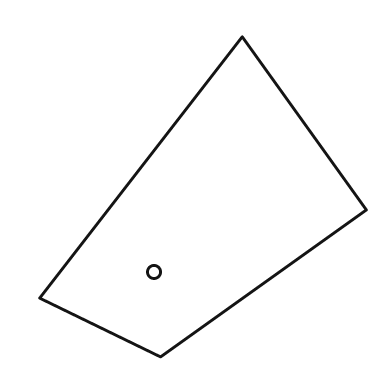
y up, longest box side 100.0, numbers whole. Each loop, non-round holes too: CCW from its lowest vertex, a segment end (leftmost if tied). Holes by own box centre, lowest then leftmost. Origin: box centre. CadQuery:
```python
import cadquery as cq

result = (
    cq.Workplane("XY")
    .moveTo(-13.0, -49.0)
    .lineTo(50.0, -4.0)
    .lineTo(12.0, 49.0)
    .lineTo(-50.0, -31.0)
    .close()
    .moveTo(-15.0, -23.0)
    .circle(2.0)
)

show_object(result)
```